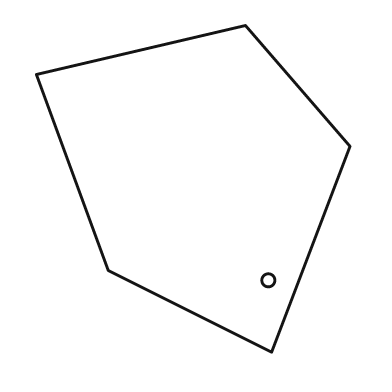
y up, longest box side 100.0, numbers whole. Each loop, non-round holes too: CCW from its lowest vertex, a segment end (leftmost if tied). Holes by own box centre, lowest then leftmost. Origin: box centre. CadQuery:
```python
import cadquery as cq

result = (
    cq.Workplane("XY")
    .moveTo(24.0, -50.0)
    .lineTo(48.0, 13.0)
    .lineTo(16.0, 50.0)
    .lineTo(-48.0, 35.0)
    .lineTo(-26.0, -25.0)
    .close()
    .moveTo(23.0, -28.0)
    .circle(2.0)
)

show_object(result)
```